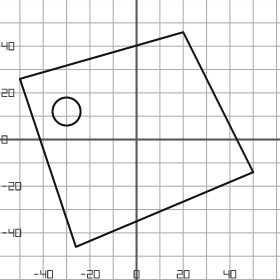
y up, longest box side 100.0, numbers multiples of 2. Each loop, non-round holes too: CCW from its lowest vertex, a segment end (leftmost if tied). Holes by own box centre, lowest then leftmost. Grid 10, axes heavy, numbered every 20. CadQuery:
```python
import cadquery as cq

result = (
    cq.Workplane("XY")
    .moveTo(-26.0, -46.0)
    .lineTo(50.0, -14.0)
    .lineTo(20.0, 46.0)
    .lineTo(-50.0, 26.0)
    .close()
    .moveTo(-30.0, 12.0)
    .circle(6.0)
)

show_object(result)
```